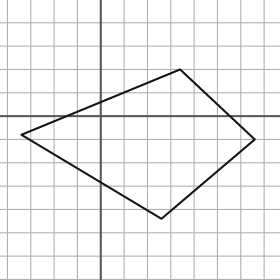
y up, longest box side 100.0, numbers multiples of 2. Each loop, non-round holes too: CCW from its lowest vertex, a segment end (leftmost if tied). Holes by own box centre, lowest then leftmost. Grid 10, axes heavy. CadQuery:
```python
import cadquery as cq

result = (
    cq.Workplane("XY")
    .moveTo(26.0, -44.0)
    .lineTo(66.0, -10.0)
    .lineTo(34.0, 20.0)
    .lineTo(-34.0, -8.0)
    .close()
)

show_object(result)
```